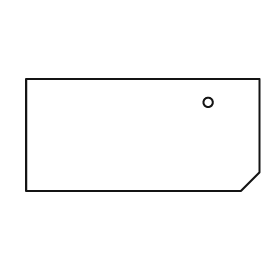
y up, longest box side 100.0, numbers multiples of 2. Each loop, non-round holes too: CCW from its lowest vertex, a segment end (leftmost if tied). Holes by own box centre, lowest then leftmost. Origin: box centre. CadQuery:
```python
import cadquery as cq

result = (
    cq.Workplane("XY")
    .moveTo(-50.0, -24.0)
    .lineTo(42.0, -24.0)
    .lineTo(50.0, -16.0)
    .lineTo(50.0, 24.0)
    .lineTo(-50.0, 24.0)
    .close()
    .moveTo(28.0, 14.0)
    .circle(2.0)
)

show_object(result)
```